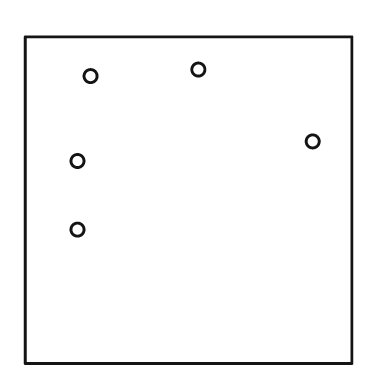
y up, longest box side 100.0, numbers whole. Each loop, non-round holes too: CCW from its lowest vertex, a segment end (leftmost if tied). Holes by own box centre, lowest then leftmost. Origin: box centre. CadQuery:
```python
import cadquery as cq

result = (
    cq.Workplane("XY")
    .moveTo(-50.0, -50.0)
    .lineTo(50.0, -50.0)
    .lineTo(50.0, 50.0)
    .lineTo(-50.0, 50.0)
    .close()
    .moveTo(-34.0, -9.0)
    .circle(2.0)
    .moveTo(-34.0, 12.0)
    .circle(2.0)
    .moveTo(38.0, 18.0)
    .circle(2.0)
    .moveTo(-30.0, 38.0)
    .circle(2.0)
    .moveTo(3.0, 40.0)
    .circle(2.0)
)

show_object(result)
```